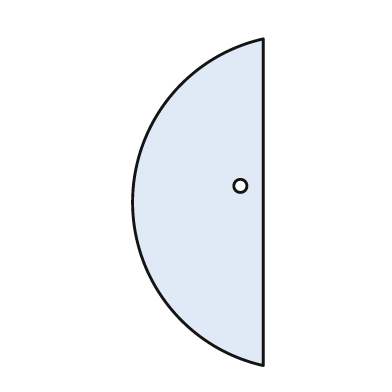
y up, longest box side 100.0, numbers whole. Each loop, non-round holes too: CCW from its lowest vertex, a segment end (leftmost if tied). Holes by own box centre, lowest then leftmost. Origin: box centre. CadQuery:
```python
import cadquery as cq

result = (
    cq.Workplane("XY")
    .moveTo(20.0, -50.0)
    .lineTo(20.0, 50.0)
    .threePointArc((-20.0, 0.0), (20.0, -50.0))
    .close()
    .moveTo(13.0, 5.0)
    .circle(2.0)
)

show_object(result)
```